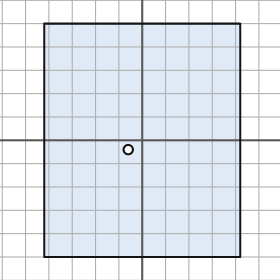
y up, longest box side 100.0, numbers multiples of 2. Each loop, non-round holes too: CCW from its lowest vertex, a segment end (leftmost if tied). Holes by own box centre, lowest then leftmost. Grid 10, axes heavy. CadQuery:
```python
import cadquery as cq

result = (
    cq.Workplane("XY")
    .moveTo(-42.0, -50.0)
    .lineTo(42.0, -50.0)
    .lineTo(42.0, 50.0)
    .lineTo(-42.0, 50.0)
    .close()
    .moveTo(-6.0, -4.0)
    .circle(2.0)
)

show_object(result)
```